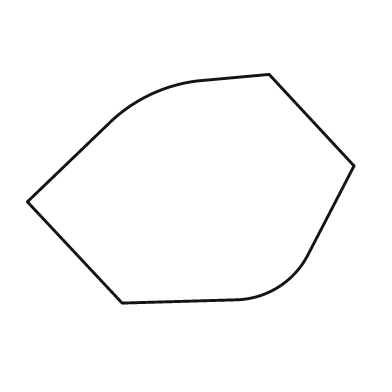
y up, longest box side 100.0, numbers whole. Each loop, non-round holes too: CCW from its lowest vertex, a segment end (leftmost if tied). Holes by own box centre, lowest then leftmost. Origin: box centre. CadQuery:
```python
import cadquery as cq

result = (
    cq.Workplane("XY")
    .moveTo(-21.0, -35.0)
    .lineTo(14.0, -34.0)
    .threePointArc((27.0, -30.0), (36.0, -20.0))
    .lineTo(50.0, 7.0)
    .lineTo(24.0, 35.0)
    .lineTo(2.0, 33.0)
    .threePointArc((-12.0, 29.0), (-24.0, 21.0))
    .lineTo(-50.0, -4.0)
    .close()
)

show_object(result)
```